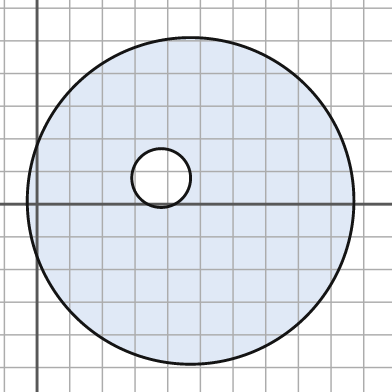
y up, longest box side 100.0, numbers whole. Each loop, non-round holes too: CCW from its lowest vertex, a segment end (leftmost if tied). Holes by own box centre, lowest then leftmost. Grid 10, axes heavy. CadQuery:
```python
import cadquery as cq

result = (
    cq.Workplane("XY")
    .moveTo(47.0, 1.0)
    .circle(50.0)
    .moveTo(38.0, 8.0)
    .circle(9.0)
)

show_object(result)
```